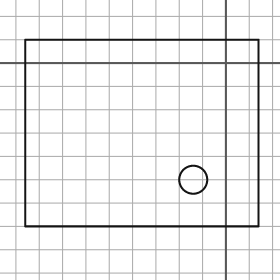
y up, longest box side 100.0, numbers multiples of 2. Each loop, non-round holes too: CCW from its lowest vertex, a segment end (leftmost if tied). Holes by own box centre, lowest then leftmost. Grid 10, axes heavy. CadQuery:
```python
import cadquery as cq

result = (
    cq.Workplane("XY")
    .moveTo(-86.0, -70.0)
    .lineTo(14.0, -70.0)
    .lineTo(14.0, 10.0)
    .lineTo(-86.0, 10.0)
    .close()
    .moveTo(-14.0, -50.0)
    .circle(6.0)
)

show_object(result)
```